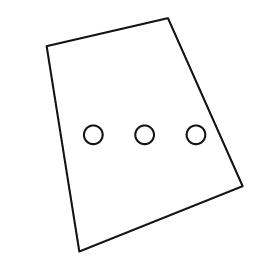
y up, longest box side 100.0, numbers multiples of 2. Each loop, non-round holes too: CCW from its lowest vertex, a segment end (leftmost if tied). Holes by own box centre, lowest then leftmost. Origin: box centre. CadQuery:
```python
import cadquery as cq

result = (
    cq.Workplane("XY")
    .moveTo(-28.0, -50.0)
    .lineTo(42.0, -22.0)
    .lineTo(10.0, 50.0)
    .lineTo(-42.0, 38.0)
    .close()
    .moveTo(-22.0, 0.0)
    .circle(4.0)
    .moveTo(0.0, 0.0)
    .circle(4.0)
    .moveTo(22.0, 0.0)
    .circle(4.0)
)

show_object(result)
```